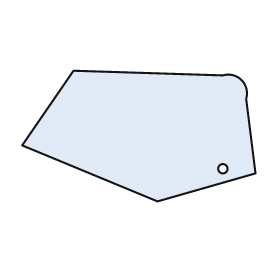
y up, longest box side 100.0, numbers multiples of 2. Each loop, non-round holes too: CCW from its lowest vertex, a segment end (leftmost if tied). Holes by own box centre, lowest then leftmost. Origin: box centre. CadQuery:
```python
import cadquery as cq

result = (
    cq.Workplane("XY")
    .moveTo(8.0, -28.0)
    .lineTo(50.0, -16.0)
    .lineTo(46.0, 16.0)
    .threePointArc((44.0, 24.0), (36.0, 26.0))
    .lineTo(-28.0, 28.0)
    .lineTo(-50.0, -4.0)
    .close()
    .moveTo(36.0, -14.0)
    .circle(2.0)
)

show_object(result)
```